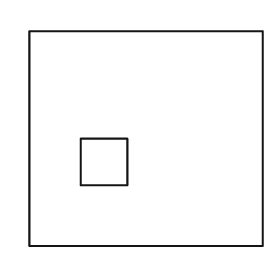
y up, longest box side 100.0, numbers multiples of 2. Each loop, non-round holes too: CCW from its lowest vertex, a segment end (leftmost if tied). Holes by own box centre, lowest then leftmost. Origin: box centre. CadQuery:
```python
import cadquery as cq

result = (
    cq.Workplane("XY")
    .moveTo(-50.0, -46.0)
    .lineTo(50.0, -46.0)
    .lineTo(50.0, 46.0)
    .lineTo(-50.0, 46.0)
    .close()
    .moveTo(-28.0, -20.0)
    .lineTo(-8.0, -20.0)
    .lineTo(-8.0, 0.0)
    .lineTo(-28.0, 0.0)
    .close()
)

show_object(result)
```